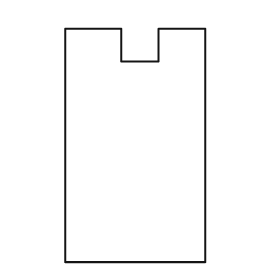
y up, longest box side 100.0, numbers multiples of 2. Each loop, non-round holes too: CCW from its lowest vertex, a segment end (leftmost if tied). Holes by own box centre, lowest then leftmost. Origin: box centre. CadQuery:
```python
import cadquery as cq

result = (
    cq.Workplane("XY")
    .moveTo(-30.0, -50.0)
    .lineTo(30.0, -50.0)
    .lineTo(30.0, 50.0)
    .lineTo(10.0, 50.0)
    .lineTo(10.0, 36.0)
    .lineTo(-6.0, 36.0)
    .lineTo(-6.0, 50.0)
    .lineTo(-30.0, 50.0)
    .close()
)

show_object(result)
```